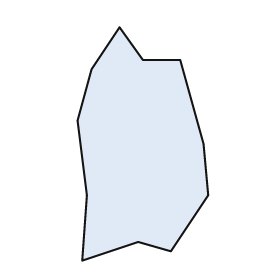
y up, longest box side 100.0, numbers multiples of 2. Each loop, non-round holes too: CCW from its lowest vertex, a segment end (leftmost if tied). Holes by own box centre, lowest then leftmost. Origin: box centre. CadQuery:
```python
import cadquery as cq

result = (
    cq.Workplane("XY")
    .moveTo(-26.0, -50.0)
    .lineTo(-2.0, -42.0)
    .lineTo(12.0, -46.0)
    .lineTo(28.0, -22.0)
    .lineTo(26.0, 0.0)
    .lineTo(16.0, 36.0)
    .lineTo(0.0, 36.0)
    .lineTo(-10.0, 50.0)
    .lineTo(-22.0, 32.0)
    .lineTo(-28.0, 10.0)
    .lineTo(-24.0, -22.0)
    .close()
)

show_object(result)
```